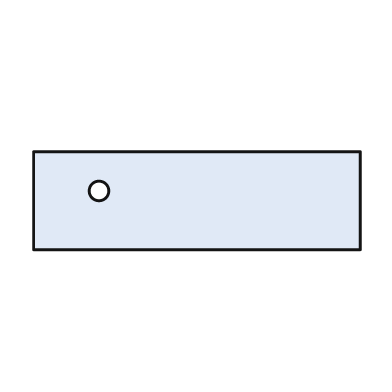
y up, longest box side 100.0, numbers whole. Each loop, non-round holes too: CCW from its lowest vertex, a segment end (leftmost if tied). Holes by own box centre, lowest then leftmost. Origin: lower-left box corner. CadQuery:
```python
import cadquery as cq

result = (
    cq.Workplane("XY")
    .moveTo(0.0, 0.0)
    .lineTo(100.0, 0.0)
    .lineTo(100.0, 30.0)
    .lineTo(0.0, 30.0)
    .close()
    .moveTo(20.0, 18.0)
    .circle(3.0)
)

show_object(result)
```